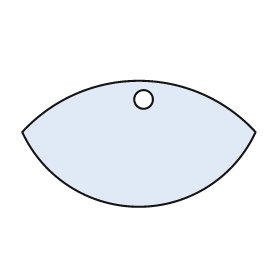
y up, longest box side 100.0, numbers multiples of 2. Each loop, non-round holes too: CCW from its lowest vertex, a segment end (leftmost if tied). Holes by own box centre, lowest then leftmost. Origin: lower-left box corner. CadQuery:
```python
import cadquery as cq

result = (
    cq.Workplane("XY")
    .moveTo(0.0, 32.0)
    .threePointArc((50.0, 0.0), (100.0, 32.0))
    .threePointArc((50.0, 54.0), (0.0, 32.0))
    .close()
    .moveTo(52.0, 46.0)
    .circle(4.0)
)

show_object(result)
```